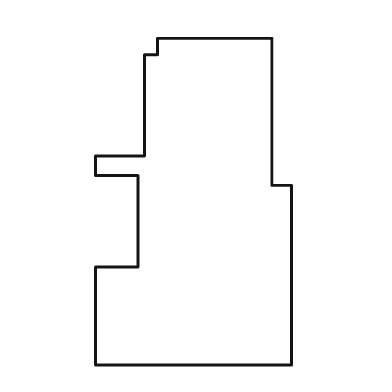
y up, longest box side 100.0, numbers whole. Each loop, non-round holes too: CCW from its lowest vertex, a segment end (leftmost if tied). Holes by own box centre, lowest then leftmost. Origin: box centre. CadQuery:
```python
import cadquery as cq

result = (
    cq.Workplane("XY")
    .moveTo(-30.0, -50.0)
    .lineTo(30.0, -50.0)
    .lineTo(30.0, 5.0)
    .lineTo(24.0, 5.0)
    .lineTo(24.0, 50.0)
    .lineTo(-11.0, 50.0)
    .lineTo(-11.0, 45.0)
    .lineTo(-15.0, 45.0)
    .lineTo(-15.0, 14.0)
    .lineTo(-30.0, 14.0)
    .lineTo(-30.0, 8.0)
    .lineTo(-17.0, 8.0)
    .lineTo(-17.0, -20.0)
    .lineTo(-30.0, -20.0)
    .close()
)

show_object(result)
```